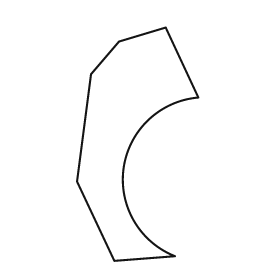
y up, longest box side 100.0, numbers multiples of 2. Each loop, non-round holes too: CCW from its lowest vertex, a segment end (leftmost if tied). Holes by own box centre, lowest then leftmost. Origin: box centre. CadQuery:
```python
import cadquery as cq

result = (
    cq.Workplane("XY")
    .moveTo(-10.0, -50.0)
    .lineTo(16.0, -48.0)
    .threePointArc((-6.0, -10.0), (26.0, 20.0))
    .lineTo(12.0, 50.0)
    .lineTo(-8.0, 44.0)
    .lineTo(-20.0, 30.0)
    .lineTo(-26.0, -16.0)
    .close()
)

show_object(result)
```